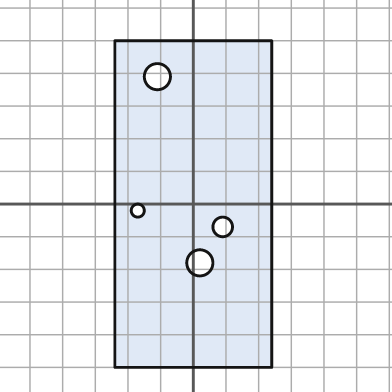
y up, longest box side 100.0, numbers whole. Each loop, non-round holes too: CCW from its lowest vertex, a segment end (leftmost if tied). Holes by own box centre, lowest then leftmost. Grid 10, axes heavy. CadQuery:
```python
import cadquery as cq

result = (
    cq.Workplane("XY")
    .moveTo(-24.0, -50.0)
    .lineTo(24.0, -50.0)
    .lineTo(24.0, 50.0)
    .lineTo(-24.0, 50.0)
    .close()
    .moveTo(2.0, -18.0)
    .circle(4.0)
    .moveTo(9.0, -7.0)
    .circle(3.0)
    .moveTo(-17.0, -2.0)
    .circle(2.0)
    .moveTo(-11.0, 39.0)
    .circle(4.0)
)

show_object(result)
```